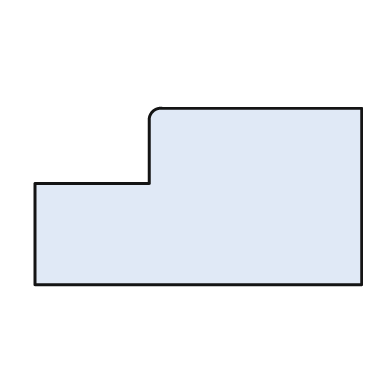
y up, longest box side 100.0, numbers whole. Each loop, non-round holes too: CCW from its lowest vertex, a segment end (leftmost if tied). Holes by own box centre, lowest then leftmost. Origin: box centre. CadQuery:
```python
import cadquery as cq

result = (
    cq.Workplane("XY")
    .moveTo(-50.0, -27.0)
    .lineTo(50.0, -27.0)
    .lineTo(50.0, 27.0)
    .lineTo(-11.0, 27.0)
    .threePointArc((-14.0, 26.0), (-15.0, 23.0))
    .lineTo(-15.0, 4.0)
    .lineTo(-50.0, 4.0)
    .close()
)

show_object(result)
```